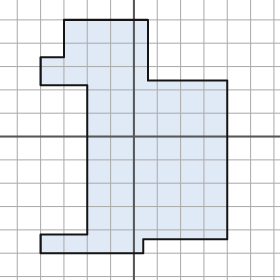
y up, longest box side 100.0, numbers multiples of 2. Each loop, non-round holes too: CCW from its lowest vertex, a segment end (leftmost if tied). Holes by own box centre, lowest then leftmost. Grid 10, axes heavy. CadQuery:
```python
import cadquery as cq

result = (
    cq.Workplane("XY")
    .moveTo(-40.0, -50.0)
    .lineTo(4.0, -50.0)
    .lineTo(4.0, -44.0)
    .lineTo(40.0, -44.0)
    .lineTo(40.0, 24.0)
    .lineTo(6.0, 24.0)
    .lineTo(6.0, 50.0)
    .lineTo(-30.0, 50.0)
    .lineTo(-30.0, 34.0)
    .lineTo(-40.0, 34.0)
    .lineTo(-40.0, 22.0)
    .lineTo(-20.0, 22.0)
    .lineTo(-20.0, -42.0)
    .lineTo(-40.0, -42.0)
    .close()
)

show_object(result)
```